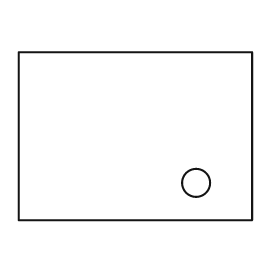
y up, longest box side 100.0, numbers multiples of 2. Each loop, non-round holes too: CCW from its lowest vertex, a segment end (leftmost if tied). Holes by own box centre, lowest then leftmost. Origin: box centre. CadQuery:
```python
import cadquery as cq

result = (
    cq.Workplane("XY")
    .moveTo(-50.0, -36.0)
    .lineTo(50.0, -36.0)
    .lineTo(50.0, 36.0)
    .lineTo(-50.0, 36.0)
    .close()
    .moveTo(26.0, -20.0)
    .circle(6.0)
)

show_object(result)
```